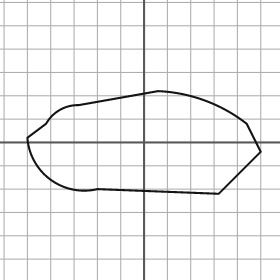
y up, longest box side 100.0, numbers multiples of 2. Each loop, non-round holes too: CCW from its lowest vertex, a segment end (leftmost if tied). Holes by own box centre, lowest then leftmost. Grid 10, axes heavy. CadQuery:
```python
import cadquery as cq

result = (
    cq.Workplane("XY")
    .moveTo(32.0, -22.0)
    .lineTo(50.0, -4.0)
    .lineTo(44.0, 8.0)
    .threePointArc((26.0, 18.0), (6.0, 22.0))
    .lineTo(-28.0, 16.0)
    .threePointArc((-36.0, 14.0), (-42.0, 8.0))
    .lineTo(-50.0, 2.0)
    .threePointArc((-40.0, -16.0), (-20.0, -20.0))
    .close()
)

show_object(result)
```